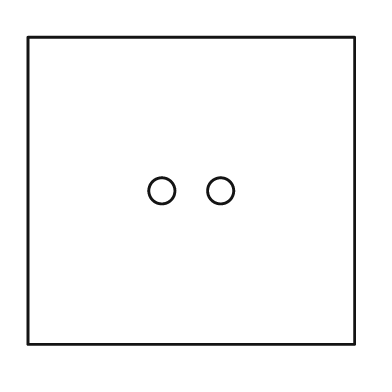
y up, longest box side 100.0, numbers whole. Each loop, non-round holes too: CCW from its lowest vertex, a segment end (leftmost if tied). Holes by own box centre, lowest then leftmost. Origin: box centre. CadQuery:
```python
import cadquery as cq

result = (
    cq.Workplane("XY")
    .moveTo(-50.0, -47.0)
    .lineTo(50.0, -47.0)
    .lineTo(50.0, 47.0)
    .lineTo(-50.0, 47.0)
    .close()
    .moveTo(-9.0, 0.0)
    .circle(4.0)
    .moveTo(9.0, 0.0)
    .circle(4.0)
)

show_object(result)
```